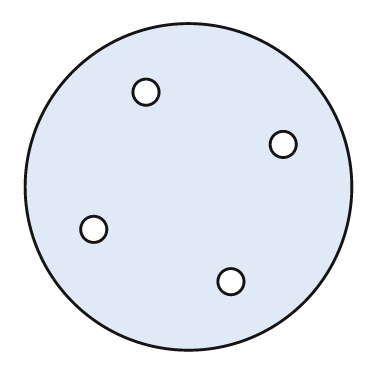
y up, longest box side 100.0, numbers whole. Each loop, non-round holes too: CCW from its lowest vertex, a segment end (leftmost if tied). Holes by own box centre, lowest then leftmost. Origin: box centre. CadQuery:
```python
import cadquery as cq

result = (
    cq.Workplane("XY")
    .moveTo(0.0, 0.0)
    .circle(50.0)
    .moveTo(13.0, -29.0)
    .circle(4.0)
    .moveTo(-29.0, -13.0)
    .circle(4.0)
    .moveTo(29.0, 13.0)
    .circle(4.0)
    .moveTo(-13.0, 29.0)
    .circle(4.0)
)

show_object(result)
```